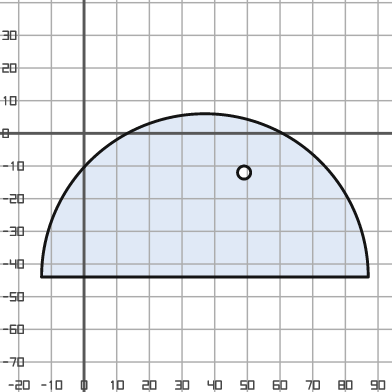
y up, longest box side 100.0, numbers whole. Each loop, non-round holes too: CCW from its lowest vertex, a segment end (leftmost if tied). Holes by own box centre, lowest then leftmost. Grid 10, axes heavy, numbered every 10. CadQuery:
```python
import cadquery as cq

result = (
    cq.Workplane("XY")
    .moveTo(-13.0, -44.0)
    .lineTo(87.0, -44.0)
    .threePointArc((37.0, 6.0), (-13.0, -44.0))
    .close()
    .moveTo(49.0, -12.0)
    .circle(2.0)
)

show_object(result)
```